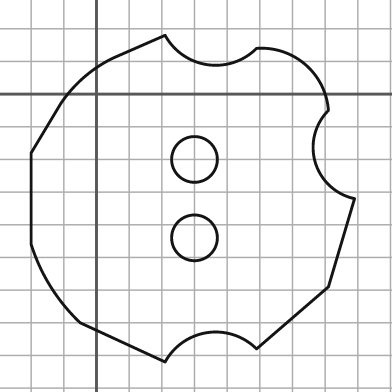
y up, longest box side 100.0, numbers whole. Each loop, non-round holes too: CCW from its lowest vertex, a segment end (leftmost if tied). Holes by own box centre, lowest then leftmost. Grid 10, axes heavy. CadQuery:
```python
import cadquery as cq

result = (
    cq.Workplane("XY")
    .moveTo(21.0, -82.0)
    .threePointArc((34.0, -73.0), (49.0, -78.0))
    .lineTo(71.0, -59.0)
    .lineTo(79.0, -32.0)
    .threePointArc((67.0, -21.0), (71.0, -5.0))
    .threePointArc((64.0, 9.0), (49.0, 14.0))
    .threePointArc((34.0, 9.0), (21.0, 18.0))
    .lineTo(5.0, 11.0)
    .threePointArc((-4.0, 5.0), (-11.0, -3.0))
    .lineTo(-20.0, -18.0)
    .lineTo(-20.0, -46.0)
    .threePointArc((-14.0, -59.0), (-5.0, -70.0))
    .close()
    .moveTo(30.0, -44.0)
    .circle(7.0)
    .moveTo(30.0, -20.0)
    .circle(7.0)
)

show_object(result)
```